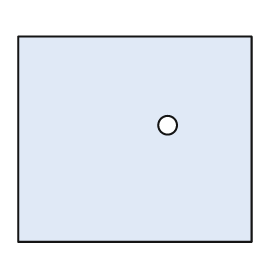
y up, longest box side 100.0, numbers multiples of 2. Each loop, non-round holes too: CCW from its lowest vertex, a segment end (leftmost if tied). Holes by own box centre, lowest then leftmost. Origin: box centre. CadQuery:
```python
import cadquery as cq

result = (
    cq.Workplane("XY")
    .moveTo(-50.0, -44.0)
    .lineTo(50.0, -44.0)
    .lineTo(50.0, 44.0)
    .lineTo(-50.0, 44.0)
    .close()
    .moveTo(14.0, 6.0)
    .circle(4.0)
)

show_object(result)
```